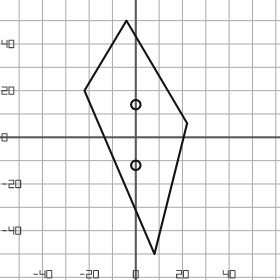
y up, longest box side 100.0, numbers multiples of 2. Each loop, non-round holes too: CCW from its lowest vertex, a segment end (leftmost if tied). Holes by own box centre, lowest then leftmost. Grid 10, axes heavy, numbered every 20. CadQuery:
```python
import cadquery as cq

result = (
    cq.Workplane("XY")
    .moveTo(8.0, -50.0)
    .lineTo(22.0, 6.0)
    .lineTo(-4.0, 50.0)
    .lineTo(-22.0, 20.0)
    .close()
    .moveTo(0.0, -12.0)
    .circle(2.0)
    .moveTo(0.0, 14.0)
    .circle(2.0)
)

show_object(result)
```